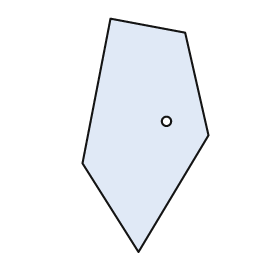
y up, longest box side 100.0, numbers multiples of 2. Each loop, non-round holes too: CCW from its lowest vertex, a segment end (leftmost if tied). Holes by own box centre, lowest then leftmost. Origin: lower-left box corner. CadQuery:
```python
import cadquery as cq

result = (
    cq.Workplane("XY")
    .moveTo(24.0, 0.0)
    .lineTo(54.0, 50.0)
    .lineTo(44.0, 94.0)
    .lineTo(12.0, 100.0)
    .lineTo(0.0, 38.0)
    .close()
    .moveTo(36.0, 56.0)
    .circle(2.0)
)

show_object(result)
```